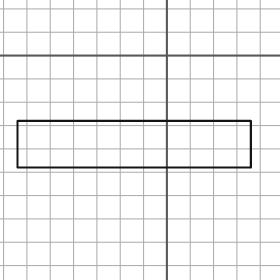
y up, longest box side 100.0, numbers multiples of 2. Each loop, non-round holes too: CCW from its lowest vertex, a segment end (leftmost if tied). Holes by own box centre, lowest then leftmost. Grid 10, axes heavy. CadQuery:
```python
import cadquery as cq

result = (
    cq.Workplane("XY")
    .moveTo(-64.0, -48.0)
    .lineTo(36.0, -48.0)
    .lineTo(36.0, -28.0)
    .lineTo(-64.0, -28.0)
    .close()
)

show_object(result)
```